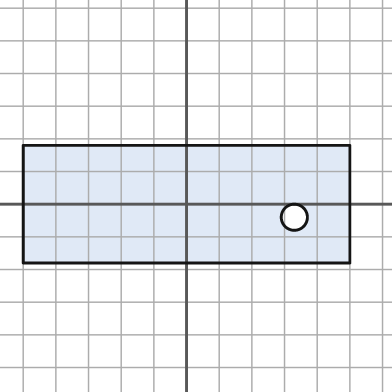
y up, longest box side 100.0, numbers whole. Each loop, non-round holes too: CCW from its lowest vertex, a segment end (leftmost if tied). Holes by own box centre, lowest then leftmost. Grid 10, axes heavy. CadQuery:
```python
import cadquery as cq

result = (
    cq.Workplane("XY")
    .moveTo(-50.0, -18.0)
    .lineTo(50.0, -18.0)
    .lineTo(50.0, 18.0)
    .lineTo(-50.0, 18.0)
    .close()
    .moveTo(33.0, -4.0)
    .circle(4.0)
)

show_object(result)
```